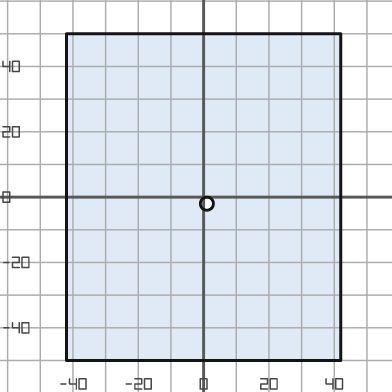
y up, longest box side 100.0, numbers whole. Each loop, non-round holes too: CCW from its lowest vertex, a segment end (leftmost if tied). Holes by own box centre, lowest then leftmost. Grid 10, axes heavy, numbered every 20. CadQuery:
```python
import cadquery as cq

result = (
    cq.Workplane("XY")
    .moveTo(-42.0, -50.0)
    .lineTo(42.0, -50.0)
    .lineTo(42.0, 50.0)
    .lineTo(-42.0, 50.0)
    .close()
    .moveTo(1.0, -2.0)
    .circle(2.0)
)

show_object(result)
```